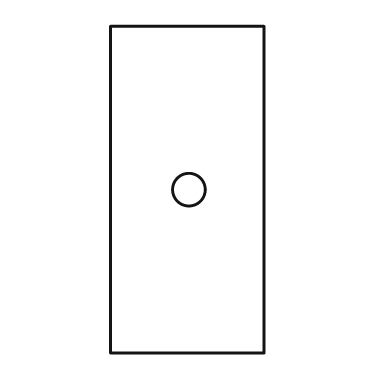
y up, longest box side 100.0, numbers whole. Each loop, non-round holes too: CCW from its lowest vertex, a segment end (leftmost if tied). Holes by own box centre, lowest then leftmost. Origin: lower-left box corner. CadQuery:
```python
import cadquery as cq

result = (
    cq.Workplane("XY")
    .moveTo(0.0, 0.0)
    .lineTo(47.0, 0.0)
    .lineTo(47.0, 100.0)
    .lineTo(0.0, 100.0)
    .close()
    .moveTo(24.0, 50.0)
    .circle(5.0)
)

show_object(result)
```